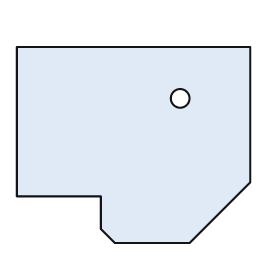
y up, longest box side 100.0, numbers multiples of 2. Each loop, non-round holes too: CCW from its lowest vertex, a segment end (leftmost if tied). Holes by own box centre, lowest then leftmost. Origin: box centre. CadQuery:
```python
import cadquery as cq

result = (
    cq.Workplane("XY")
    .moveTo(-8.0, -42.0)
    .lineTo(24.0, -42.0)
    .lineTo(50.0, -16.0)
    .lineTo(50.0, 42.0)
    .lineTo(-50.0, 42.0)
    .lineTo(-50.0, -22.0)
    .lineTo(-14.0, -22.0)
    .lineTo(-14.0, -36.0)
    .close()
    .moveTo(20.0, 20.0)
    .circle(4.0)
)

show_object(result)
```